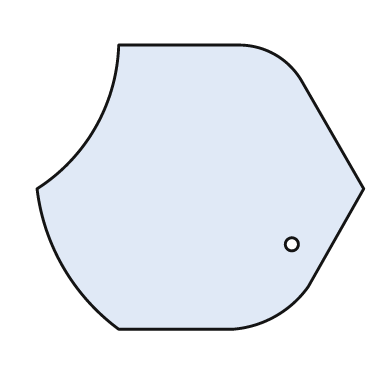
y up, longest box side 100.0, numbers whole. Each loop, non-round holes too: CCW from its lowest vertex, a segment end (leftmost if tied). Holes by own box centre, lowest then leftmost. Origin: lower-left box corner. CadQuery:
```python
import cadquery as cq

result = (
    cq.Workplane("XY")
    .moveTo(25.0, 0.0)
    .lineTo(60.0, 0.0)
    .threePointArc((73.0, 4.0), (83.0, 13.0))
    .lineTo(100.0, 43.0)
    .lineTo(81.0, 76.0)
    .threePointArc((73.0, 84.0), (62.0, 87.0))
    .lineTo(25.0, 87.0)
    .threePointArc((18.0, 62.0), (0.0, 43.0))
    .threePointArc((8.0, 19.0), (25.0, 0.0))
    .close()
    .moveTo(78.0, 26.0)
    .circle(2.0)
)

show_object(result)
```